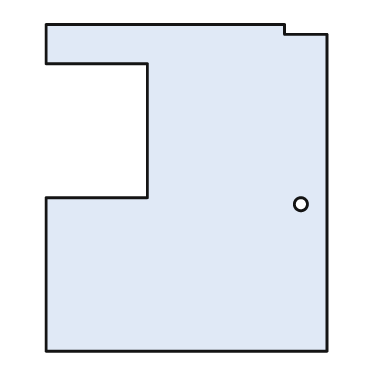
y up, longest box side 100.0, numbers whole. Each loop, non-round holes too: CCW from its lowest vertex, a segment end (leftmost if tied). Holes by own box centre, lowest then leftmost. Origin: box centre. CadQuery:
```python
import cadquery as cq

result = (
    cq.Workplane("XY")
    .moveTo(-43.0, -50.0)
    .lineTo(43.0, -50.0)
    .lineTo(43.0, 47.0)
    .lineTo(30.0, 47.0)
    .lineTo(30.0, 50.0)
    .lineTo(-43.0, 50.0)
    .lineTo(-43.0, 38.0)
    .lineTo(-12.0, 38.0)
    .lineTo(-12.0, -3.0)
    .lineTo(-43.0, -3.0)
    .close()
    .moveTo(35.0, -5.0)
    .circle(2.0)
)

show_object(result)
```